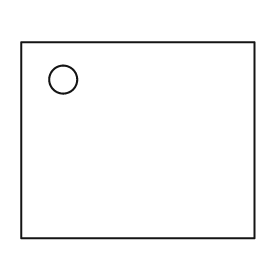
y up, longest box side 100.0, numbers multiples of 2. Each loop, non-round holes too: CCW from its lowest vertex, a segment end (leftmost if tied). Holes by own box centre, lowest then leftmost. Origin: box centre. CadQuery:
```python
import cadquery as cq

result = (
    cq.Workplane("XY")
    .moveTo(-50.0, -42.0)
    .lineTo(50.0, -42.0)
    .lineTo(50.0, 42.0)
    .lineTo(-50.0, 42.0)
    .close()
    .moveTo(-32.0, 26.0)
    .circle(6.0)
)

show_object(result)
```